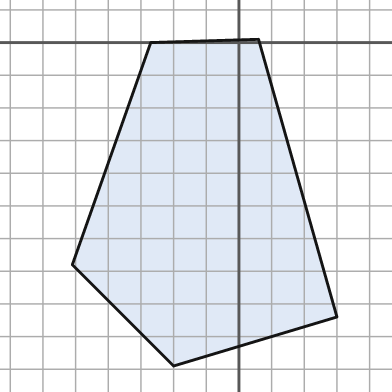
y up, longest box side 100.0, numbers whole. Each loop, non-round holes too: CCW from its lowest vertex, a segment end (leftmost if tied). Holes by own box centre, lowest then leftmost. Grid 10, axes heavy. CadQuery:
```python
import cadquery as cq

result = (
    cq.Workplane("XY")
    .moveTo(-20.0, -99.0)
    .lineTo(30.0, -84.0)
    .lineTo(6.0, 1.0)
    .lineTo(-27.0, 0.0)
    .lineTo(-51.0, -68.0)
    .close()
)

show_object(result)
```